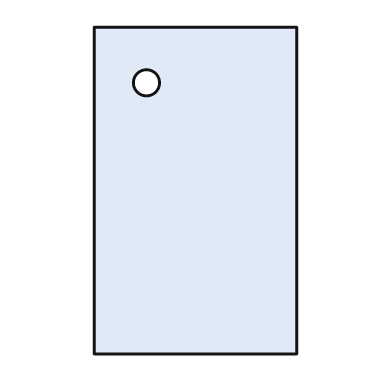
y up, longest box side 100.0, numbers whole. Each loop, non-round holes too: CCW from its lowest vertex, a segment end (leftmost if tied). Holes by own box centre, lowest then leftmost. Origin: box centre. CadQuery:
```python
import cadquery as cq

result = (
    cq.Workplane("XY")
    .moveTo(-31.0, -50.0)
    .lineTo(31.0, -50.0)
    .lineTo(31.0, 50.0)
    .lineTo(-31.0, 50.0)
    .close()
    .moveTo(-15.0, 33.0)
    .circle(4.0)
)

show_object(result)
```